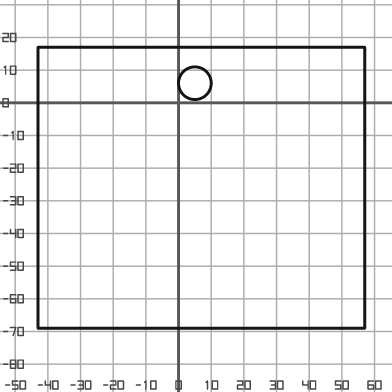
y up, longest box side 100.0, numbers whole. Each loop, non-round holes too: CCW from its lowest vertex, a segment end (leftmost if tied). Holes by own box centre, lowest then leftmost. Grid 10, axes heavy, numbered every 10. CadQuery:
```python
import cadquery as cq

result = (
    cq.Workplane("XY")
    .moveTo(-43.0, -69.0)
    .lineTo(57.0, -69.0)
    .lineTo(57.0, 17.0)
    .lineTo(-43.0, 17.0)
    .close()
    .moveTo(5.0, 6.0)
    .circle(5.0)
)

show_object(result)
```